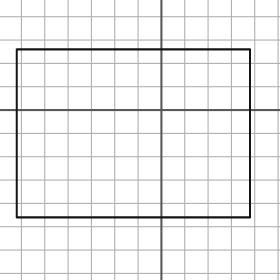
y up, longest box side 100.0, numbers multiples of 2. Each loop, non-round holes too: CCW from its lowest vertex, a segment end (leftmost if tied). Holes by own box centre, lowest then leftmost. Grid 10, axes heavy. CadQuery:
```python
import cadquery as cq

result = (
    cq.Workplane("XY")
    .moveTo(-62.0, -46.0)
    .lineTo(38.0, -46.0)
    .lineTo(38.0, 26.0)
    .lineTo(-62.0, 26.0)
    .close()
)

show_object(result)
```